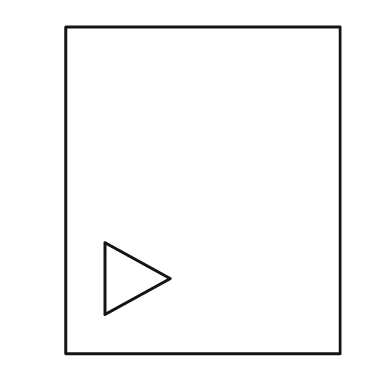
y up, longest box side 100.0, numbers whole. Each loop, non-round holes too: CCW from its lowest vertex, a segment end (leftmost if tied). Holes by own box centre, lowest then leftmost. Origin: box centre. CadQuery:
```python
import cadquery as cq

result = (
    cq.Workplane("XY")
    .moveTo(-42.0, -50.0)
    .lineTo(42.0, -50.0)
    .lineTo(42.0, 50.0)
    .lineTo(-42.0, 50.0)
    .close()
    .moveTo(-30.0, -38.0)
    .lineTo(-10.0, -27.0)
    .lineTo(-30.0, -16.0)
    .close()
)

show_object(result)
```